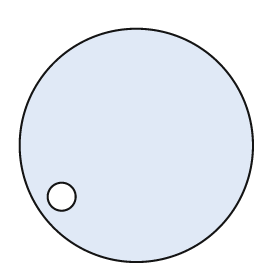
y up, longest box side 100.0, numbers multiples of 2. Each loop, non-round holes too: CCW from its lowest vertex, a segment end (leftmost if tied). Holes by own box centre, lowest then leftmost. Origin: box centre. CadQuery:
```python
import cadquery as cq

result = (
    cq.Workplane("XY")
    .moveTo(0.0, 0.0)
    .circle(50.0)
    .moveTo(-32.0, -22.0)
    .circle(6.0)
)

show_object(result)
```